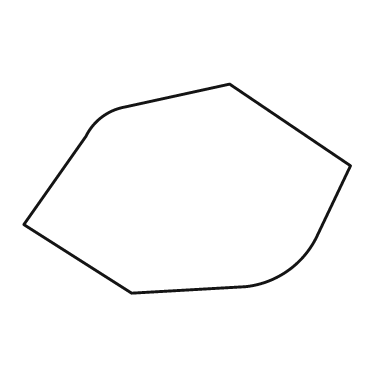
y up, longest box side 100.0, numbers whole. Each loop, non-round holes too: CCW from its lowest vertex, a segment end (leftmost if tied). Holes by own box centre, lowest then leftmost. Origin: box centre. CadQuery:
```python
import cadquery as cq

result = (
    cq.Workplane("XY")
    .moveTo(-17.0, -32.0)
    .lineTo(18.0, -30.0)
    .threePointArc((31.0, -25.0), (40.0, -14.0))
    .lineTo(50.0, 7.0)
    .lineTo(13.0, 32.0)
    .lineTo(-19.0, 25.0)
    .threePointArc((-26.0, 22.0), (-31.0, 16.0))
    .lineTo(-50.0, -11.0)
    .close()
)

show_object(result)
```